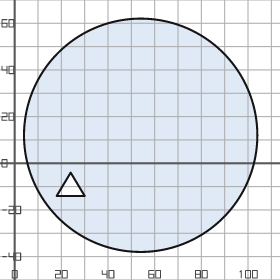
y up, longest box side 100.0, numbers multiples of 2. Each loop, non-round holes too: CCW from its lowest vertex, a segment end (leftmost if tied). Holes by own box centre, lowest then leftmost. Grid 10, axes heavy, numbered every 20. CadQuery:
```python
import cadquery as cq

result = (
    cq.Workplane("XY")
    .moveTo(54.0, 12.0)
    .circle(50.0)
    .moveTo(18.0, -14.0)
    .lineTo(30.0, -14.0)
    .lineTo(24.0, -4.0)
    .close()
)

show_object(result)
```